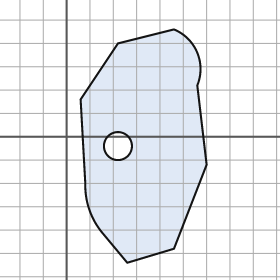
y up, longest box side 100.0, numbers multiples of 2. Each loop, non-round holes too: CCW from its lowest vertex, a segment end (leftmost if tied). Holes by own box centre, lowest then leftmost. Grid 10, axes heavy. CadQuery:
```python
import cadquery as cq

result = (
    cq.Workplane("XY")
    .moveTo(26.0, -54.0)
    .lineTo(46.0, -48.0)
    .lineTo(60.0, -12.0)
    .lineTo(56.0, 22.0)
    .threePointArc((56.0, 36.0), (46.0, 46.0))
    .lineTo(22.0, 40.0)
    .lineTo(6.0, 16.0)
    .lineTo(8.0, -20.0)
    .threePointArc((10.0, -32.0), (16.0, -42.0))
    .close()
    .moveTo(22.0, -4.0)
    .circle(6.0)
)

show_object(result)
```